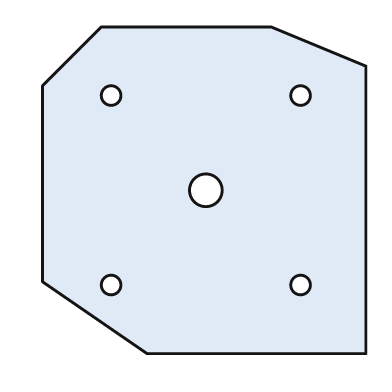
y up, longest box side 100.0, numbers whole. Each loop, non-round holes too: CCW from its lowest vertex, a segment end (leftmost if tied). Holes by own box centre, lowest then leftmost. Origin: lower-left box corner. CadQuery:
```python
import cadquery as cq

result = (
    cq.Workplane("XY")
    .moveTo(32.0, 0.0)
    .lineTo(99.0, 0.0)
    .lineTo(99.0, 88.0)
    .lineTo(70.0, 100.0)
    .lineTo(18.0, 100.0)
    .lineTo(0.0, 82.0)
    .lineTo(0.0, 22.0)
    .close()
    .moveTo(21.0, 21.0)
    .circle(3.0)
    .moveTo(79.0, 21.0)
    .circle(3.0)
    .moveTo(50.0, 50.0)
    .circle(5.0)
    .moveTo(21.0, 79.0)
    .circle(3.0)
    .moveTo(79.0, 79.0)
    .circle(3.0)
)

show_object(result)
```